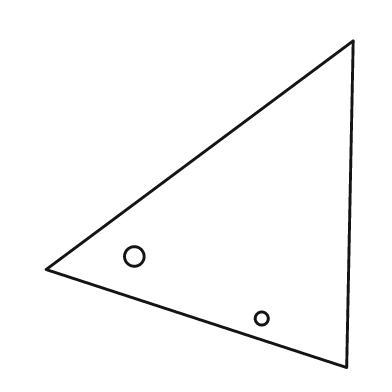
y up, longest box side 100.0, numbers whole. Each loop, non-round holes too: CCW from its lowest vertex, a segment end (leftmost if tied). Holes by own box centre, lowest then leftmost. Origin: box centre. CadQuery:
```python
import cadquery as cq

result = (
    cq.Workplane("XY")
    .moveTo(45.0, -50.0)
    .lineTo(47.0, 50.0)
    .lineTo(-47.0, -20.0)
    .close()
    .moveTo(19.0, -35.0)
    .circle(2.0)
    .moveTo(-20.0, -16.0)
    .circle(3.0)
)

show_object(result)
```